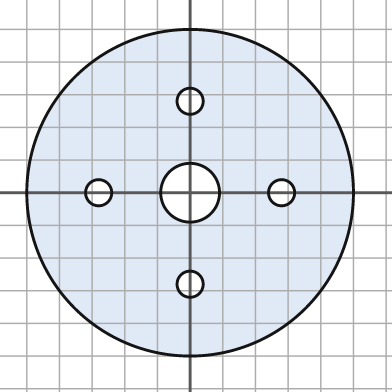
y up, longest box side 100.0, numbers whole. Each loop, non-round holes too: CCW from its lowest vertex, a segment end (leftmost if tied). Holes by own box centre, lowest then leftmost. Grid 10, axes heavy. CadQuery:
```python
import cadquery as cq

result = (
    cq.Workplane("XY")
    .moveTo(0.0, 0.0)
    .circle(50.0)
    .moveTo(0.0, -28.0)
    .circle(4.0)
    .moveTo(-28.0, 0.0)
    .circle(4.0)
    .moveTo(0.0, 0.0)
    .circle(9.0)
    .moveTo(28.0, 0.0)
    .circle(4.0)
    .moveTo(0.0, 28.0)
    .circle(4.0)
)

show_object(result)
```